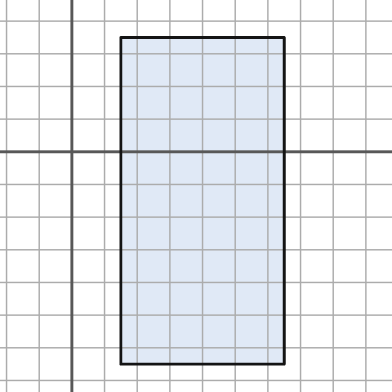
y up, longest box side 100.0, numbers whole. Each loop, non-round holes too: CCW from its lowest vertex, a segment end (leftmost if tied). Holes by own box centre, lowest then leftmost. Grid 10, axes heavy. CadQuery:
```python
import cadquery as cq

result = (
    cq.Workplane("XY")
    .moveTo(15.0, -65.0)
    .lineTo(65.0, -65.0)
    .lineTo(65.0, 35.0)
    .lineTo(15.0, 35.0)
    .close()
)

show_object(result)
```